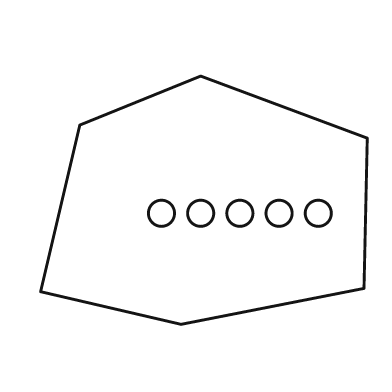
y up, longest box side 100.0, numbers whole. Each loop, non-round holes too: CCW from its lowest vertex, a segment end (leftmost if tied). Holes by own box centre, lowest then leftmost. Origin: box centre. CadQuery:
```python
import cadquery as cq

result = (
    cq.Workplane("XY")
    .moveTo(-7.0, -38.0)
    .lineTo(49.0, -27.0)
    .lineTo(50.0, 19.0)
    .lineTo(-1.0, 38.0)
    .lineTo(-38.0, 23.0)
    .lineTo(-50.0, -28.0)
    .close()
    .moveTo(-13.0, -4.0)
    .circle(4.0)
    .moveTo(-1.0, -4.0)
    .circle(4.0)
    .moveTo(11.0, -4.0)
    .circle(4.0)
    .moveTo(23.0, -4.0)
    .circle(4.0)
    .moveTo(35.0, -4.0)
    .circle(4.0)
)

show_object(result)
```